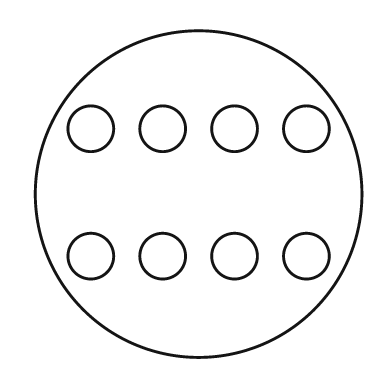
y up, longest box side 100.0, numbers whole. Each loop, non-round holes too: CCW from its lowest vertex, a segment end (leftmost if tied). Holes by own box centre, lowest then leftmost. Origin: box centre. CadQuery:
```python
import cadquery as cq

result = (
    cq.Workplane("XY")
    .moveTo(0.0, 0.0)
    .circle(50.0)
    .moveTo(-33.0, -19.0)
    .circle(7.0)
    .moveTo(-11.0, -19.0)
    .circle(7.0)
    .moveTo(11.0, -19.0)
    .circle(7.0)
    .moveTo(33.0, -19.0)
    .circle(7.0)
    .moveTo(-33.0, 20.0)
    .circle(7.0)
    .moveTo(-11.0, 20.0)
    .circle(7.0)
    .moveTo(11.0, 20.0)
    .circle(7.0)
    .moveTo(33.0, 20.0)
    .circle(7.0)
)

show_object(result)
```